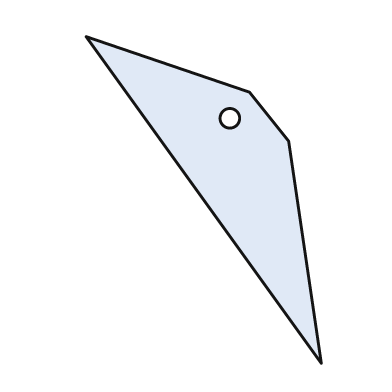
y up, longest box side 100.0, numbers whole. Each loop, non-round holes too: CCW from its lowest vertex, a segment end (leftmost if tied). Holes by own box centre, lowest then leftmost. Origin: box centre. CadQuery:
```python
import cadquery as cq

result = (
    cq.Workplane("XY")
    .moveTo(36.0, -50.0)
    .lineTo(26.0, 18.0)
    .lineTo(14.0, 33.0)
    .lineTo(-36.0, 50.0)
    .close()
    .moveTo(8.0, 25.0)
    .circle(3.0)
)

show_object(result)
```